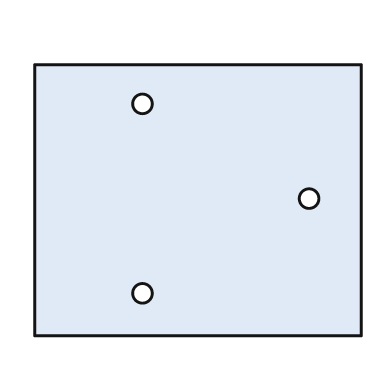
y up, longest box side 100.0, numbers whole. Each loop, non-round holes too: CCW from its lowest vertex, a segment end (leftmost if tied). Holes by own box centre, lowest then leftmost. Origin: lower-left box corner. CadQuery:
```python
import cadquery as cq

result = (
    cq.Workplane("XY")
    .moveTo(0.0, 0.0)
    .lineTo(100.0, 0.0)
    .lineTo(100.0, 83.0)
    .lineTo(0.0, 83.0)
    .close()
    .moveTo(33.0, 13.0)
    .circle(3.0)
    .moveTo(84.0, 42.0)
    .circle(3.0)
    .moveTo(33.0, 71.0)
    .circle(3.0)
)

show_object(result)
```